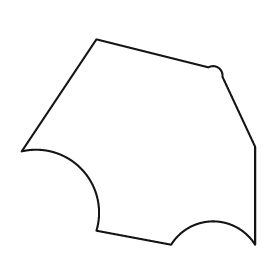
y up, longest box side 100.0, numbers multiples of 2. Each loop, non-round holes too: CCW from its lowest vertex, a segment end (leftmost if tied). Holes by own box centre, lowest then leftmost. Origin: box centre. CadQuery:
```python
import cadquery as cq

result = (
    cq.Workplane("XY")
    .moveTo(14.0, -44.0)
    .threePointArc((32.0, -34.0), (50.0, -44.0))
    .lineTo(50.0, -2.0)
    .lineTo(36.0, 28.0)
    .threePointArc((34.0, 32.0), (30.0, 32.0))
    .lineTo(-18.0, 44.0)
    .lineTo(-50.0, -4.0)
    .threePointArc((-24.0, -12.0), (-18.0, -38.0))
    .close()
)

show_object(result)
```